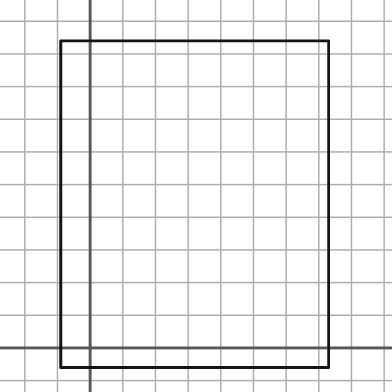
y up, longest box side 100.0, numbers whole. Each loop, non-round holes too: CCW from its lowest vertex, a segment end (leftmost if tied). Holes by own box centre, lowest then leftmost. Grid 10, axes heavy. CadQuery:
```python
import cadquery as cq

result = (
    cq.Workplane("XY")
    .moveTo(-9.0, -6.0)
    .lineTo(73.0, -6.0)
    .lineTo(73.0, 94.0)
    .lineTo(-9.0, 94.0)
    .close()
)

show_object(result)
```